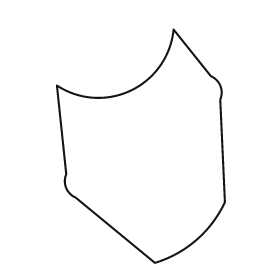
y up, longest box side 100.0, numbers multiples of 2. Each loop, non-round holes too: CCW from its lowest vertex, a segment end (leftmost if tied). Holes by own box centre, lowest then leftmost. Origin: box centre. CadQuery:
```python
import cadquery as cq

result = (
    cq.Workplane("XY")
    .moveTo(6.0, -50.0)
    .threePointArc((24.0, -40.0), (36.0, -24.0))
    .lineTo(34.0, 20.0)
    .threePointArc((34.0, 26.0), (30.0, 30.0))
    .lineTo(14.0, 50.0)
    .threePointArc((-4.0, 24.0), (-36.0, 26.0))
    .lineTo(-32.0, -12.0)
    .threePointArc((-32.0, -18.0), (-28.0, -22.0))
    .close()
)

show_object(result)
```